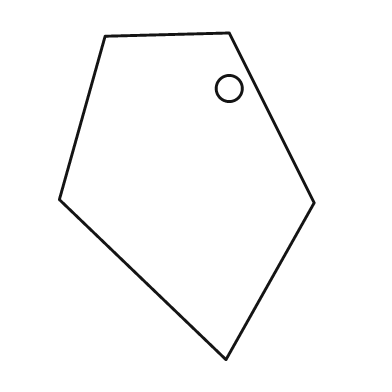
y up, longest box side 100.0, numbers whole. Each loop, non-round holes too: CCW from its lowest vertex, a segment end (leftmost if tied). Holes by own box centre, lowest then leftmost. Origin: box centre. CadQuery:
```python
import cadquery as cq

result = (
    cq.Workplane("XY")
    .moveTo(12.0, -50.0)
    .lineTo(39.0, -2.0)
    .lineTo(13.0, 50.0)
    .lineTo(-25.0, 49.0)
    .lineTo(-39.0, -1.0)
    .close()
    .moveTo(13.0, 33.0)
    .circle(4.0)
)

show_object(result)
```